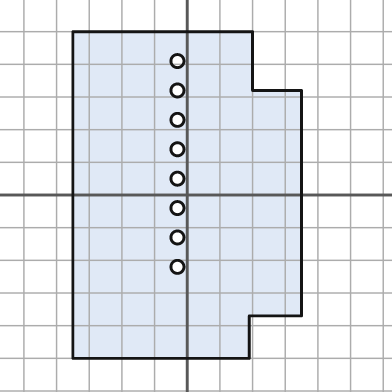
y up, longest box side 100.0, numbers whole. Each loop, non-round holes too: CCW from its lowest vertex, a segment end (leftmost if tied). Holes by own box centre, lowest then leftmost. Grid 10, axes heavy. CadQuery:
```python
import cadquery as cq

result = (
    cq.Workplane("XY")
    .moveTo(-35.0, -50.0)
    .lineTo(19.0, -50.0)
    .lineTo(19.0, -37.0)
    .lineTo(35.0, -37.0)
    .lineTo(35.0, 32.0)
    .lineTo(20.0, 32.0)
    .lineTo(20.0, 50.0)
    .lineTo(-35.0, 50.0)
    .close()
    .moveTo(-3.0, -22.0)
    .circle(2.0)
    .moveTo(-3.0, -13.0)
    .circle(2.0)
    .moveTo(-3.0, -4.0)
    .circle(2.0)
    .moveTo(-3.0, 5.0)
    .circle(2.0)
    .moveTo(-3.0, 14.0)
    .circle(2.0)
    .moveTo(-3.0, 23.0)
    .circle(2.0)
    .moveTo(-3.0, 32.0)
    .circle(2.0)
    .moveTo(-3.0, 41.0)
    .circle(2.0)
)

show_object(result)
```